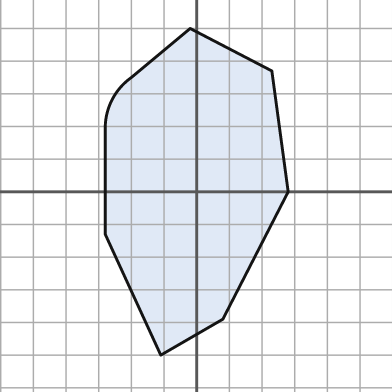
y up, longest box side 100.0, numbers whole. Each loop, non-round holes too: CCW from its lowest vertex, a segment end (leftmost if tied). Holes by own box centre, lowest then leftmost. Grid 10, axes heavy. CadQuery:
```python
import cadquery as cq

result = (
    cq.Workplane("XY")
    .moveTo(-11.0, -50.0)
    .lineTo(8.0, -39.0)
    .lineTo(28.0, 0.0)
    .lineTo(23.0, 37.0)
    .lineTo(-2.0, 50.0)
    .lineTo(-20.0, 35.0)
    .threePointArc((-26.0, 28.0), (-28.0, 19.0))
    .lineTo(-28.0, -13.0)
    .close()
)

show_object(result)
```